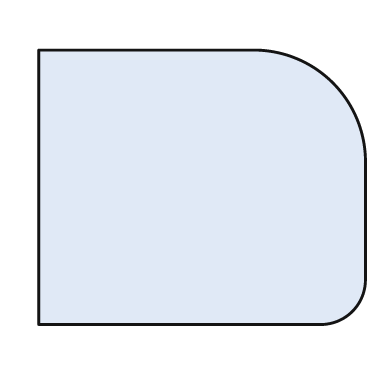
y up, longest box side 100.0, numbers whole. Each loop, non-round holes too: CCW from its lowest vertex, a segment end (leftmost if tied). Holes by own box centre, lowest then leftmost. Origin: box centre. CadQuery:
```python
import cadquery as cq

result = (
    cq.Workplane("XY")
    .moveTo(-50.0, -42.0)
    .lineTo(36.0, -42.0)
    .threePointArc((46.0, -38.0), (50.0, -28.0))
    .lineTo(50.0, 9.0)
    .threePointArc((40.0, 32.0), (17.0, 42.0))
    .lineTo(-50.0, 42.0)
    .close()
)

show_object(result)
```